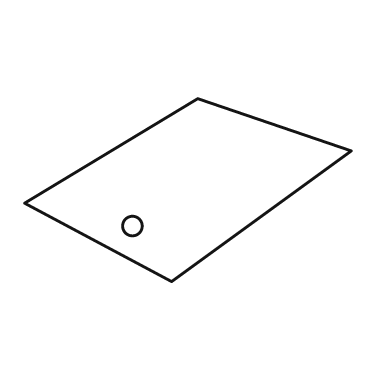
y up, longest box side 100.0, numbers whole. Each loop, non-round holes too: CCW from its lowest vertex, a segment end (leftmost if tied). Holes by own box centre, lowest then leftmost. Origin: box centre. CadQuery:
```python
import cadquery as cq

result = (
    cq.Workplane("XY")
    .moveTo(-5.0, -28.0)
    .lineTo(50.0, 12.0)
    .lineTo(3.0, 28.0)
    .lineTo(-50.0, -4.0)
    .close()
    .moveTo(-17.0, -11.0)
    .circle(3.0)
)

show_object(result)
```